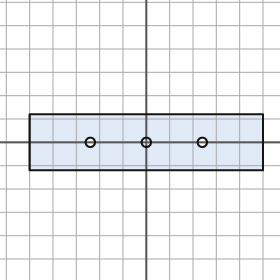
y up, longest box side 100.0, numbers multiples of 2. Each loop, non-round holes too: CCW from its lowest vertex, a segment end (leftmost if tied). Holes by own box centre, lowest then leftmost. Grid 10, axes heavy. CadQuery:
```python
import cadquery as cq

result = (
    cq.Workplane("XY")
    .moveTo(-50.0, -12.0)
    .lineTo(50.0, -12.0)
    .lineTo(50.0, 12.0)
    .lineTo(-50.0, 12.0)
    .close()
    .moveTo(-24.0, 0.0)
    .circle(2.0)
    .moveTo(0.0, 0.0)
    .circle(2.0)
    .moveTo(24.0, 0.0)
    .circle(2.0)
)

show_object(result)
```